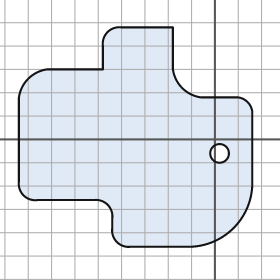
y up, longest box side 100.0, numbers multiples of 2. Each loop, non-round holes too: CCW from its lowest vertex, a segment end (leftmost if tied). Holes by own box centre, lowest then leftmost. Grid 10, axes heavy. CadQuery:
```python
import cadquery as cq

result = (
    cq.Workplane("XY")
    .moveTo(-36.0, -46.0)
    .lineTo(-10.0, -46.0)
    .threePointArc((8.0, -38.0), (16.0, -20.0))
    .lineTo(16.0, 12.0)
    .threePointArc((14.0, 16.0), (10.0, 18.0))
    .lineTo(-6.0, 18.0)
    .threePointArc((-14.0, 22.0), (-18.0, 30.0))
    .lineTo(-18.0, 48.0)
    .lineTo(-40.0, 48.0)
    .threePointArc((-46.0, 46.0), (-48.0, 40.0))
    .lineTo(-48.0, 30.0)
    .lineTo(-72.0, 30.0)
    .threePointArc((-80.0, 26.0), (-84.0, 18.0))
    .lineTo(-84.0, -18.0)
    .threePointArc((-82.0, -24.0), (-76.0, -26.0))
    .lineTo(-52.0, -26.0)
    .threePointArc((-46.0, -28.0), (-44.0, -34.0))
    .lineTo(-44.0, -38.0)
    .threePointArc((-42.0, -44.0), (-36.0, -46.0))
    .close()
    .moveTo(2.0, -6.0)
    .circle(4.0)
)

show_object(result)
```